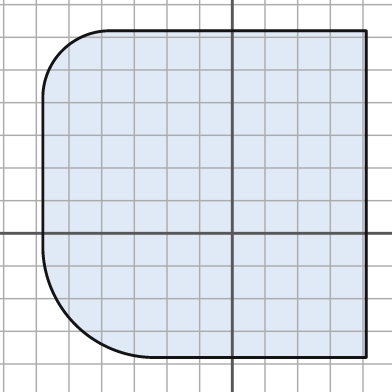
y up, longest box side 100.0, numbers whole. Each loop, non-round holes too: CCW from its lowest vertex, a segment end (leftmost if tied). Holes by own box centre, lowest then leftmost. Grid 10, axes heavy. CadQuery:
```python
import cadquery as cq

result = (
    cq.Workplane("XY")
    .moveTo(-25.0, -38.0)
    .lineTo(41.0, -38.0)
    .lineTo(41.0, 62.0)
    .lineTo(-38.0, 62.0)
    .threePointArc((-52.0, 56.0), (-58.0, 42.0))
    .lineTo(-58.0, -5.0)
    .threePointArc((-48.0, -28.0), (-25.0, -38.0))
    .close()
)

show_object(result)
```